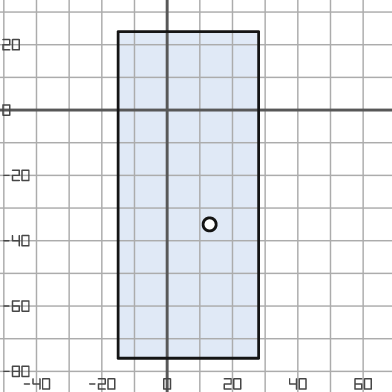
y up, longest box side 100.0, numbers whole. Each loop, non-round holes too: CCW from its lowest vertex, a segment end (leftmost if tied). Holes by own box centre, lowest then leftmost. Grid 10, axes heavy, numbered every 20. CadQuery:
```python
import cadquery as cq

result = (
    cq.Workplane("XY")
    .moveTo(-15.0, -76.0)
    .lineTo(28.0, -76.0)
    .lineTo(28.0, 24.0)
    .lineTo(-15.0, 24.0)
    .close()
    .moveTo(13.0, -35.0)
    .circle(2.0)
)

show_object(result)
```